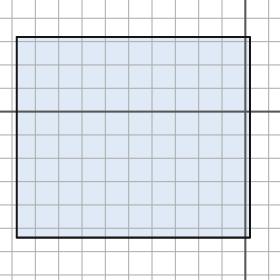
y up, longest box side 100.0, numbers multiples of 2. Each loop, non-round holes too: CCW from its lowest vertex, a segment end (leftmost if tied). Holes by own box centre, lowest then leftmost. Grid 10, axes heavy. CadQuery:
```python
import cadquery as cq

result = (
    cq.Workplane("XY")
    .moveTo(-98.0, -54.0)
    .lineTo(2.0, -54.0)
    .lineTo(2.0, 32.0)
    .lineTo(-98.0, 32.0)
    .close()
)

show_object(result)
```